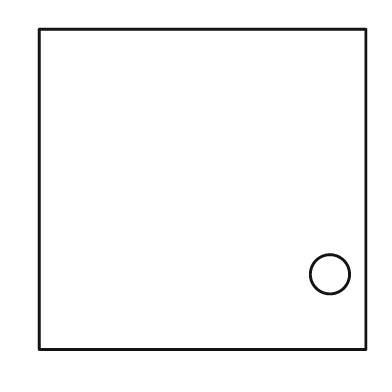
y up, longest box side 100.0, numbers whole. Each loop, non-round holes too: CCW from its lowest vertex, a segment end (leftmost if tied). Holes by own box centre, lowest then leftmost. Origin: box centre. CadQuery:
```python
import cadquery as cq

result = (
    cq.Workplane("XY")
    .moveTo(-50.0, -49.0)
    .lineTo(50.0, -49.0)
    .lineTo(50.0, 49.0)
    .lineTo(-50.0, 49.0)
    .close()
    .moveTo(39.0, -26.0)
    .circle(6.0)
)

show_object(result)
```